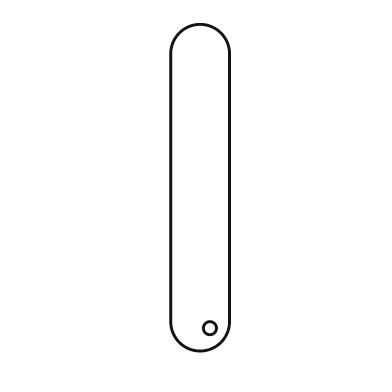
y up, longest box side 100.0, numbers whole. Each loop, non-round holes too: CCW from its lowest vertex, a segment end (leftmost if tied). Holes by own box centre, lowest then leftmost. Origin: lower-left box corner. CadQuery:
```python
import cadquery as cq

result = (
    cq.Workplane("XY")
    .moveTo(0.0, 9.0)
    .threePointArc((9.0, 0.0), (18.0, 9.0))
    .lineTo(18.0, 91.0)
    .threePointArc((9.0, 100.0), (0.0, 91.0))
    .close()
    .moveTo(12.0, 7.0)
    .circle(2.0)
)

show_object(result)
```